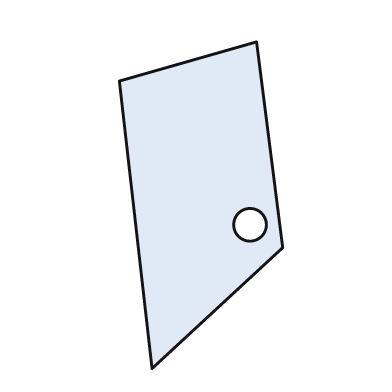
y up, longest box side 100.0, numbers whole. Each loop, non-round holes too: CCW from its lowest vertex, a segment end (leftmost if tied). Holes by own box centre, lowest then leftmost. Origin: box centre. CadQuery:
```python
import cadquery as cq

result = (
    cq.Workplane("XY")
    .moveTo(-15.0, -50.0)
    .lineTo(25.0, -13.0)
    .lineTo(17.0, 50.0)
    .lineTo(-25.0, 38.0)
    .close()
    .moveTo(15.0, -6.0)
    .circle(5.0)
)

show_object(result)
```